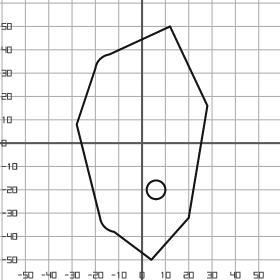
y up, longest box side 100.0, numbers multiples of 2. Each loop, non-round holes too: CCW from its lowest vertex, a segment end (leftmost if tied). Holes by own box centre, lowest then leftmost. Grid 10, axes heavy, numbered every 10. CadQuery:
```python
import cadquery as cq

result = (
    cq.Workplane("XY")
    .moveTo(4.0, -50.0)
    .lineTo(20.0, -32.0)
    .lineTo(28.0, 16.0)
    .lineTo(12.0, 50.0)
    .lineTo(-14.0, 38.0)
    .threePointArc((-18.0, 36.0), (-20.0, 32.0))
    .lineTo(-28.0, 8.0)
    .lineTo(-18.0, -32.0)
    .threePointArc((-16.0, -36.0), (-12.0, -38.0))
    .close()
    .moveTo(6.0, -20.0)
    .circle(4.0)
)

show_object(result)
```